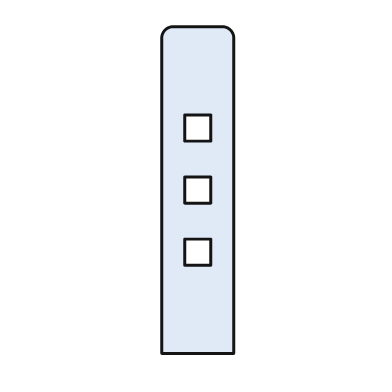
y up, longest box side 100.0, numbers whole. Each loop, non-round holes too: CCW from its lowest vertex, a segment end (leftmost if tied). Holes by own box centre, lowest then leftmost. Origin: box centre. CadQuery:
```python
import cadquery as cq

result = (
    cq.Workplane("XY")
    .moveTo(-11.0, -50.0)
    .lineTo(11.0, -50.0)
    .lineTo(11.0, 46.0)
    .threePointArc((10.0, 49.0), (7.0, 50.0))
    .lineTo(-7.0, 50.0)
    .threePointArc((-10.0, 49.0), (-11.0, 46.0))
    .close()
    .moveTo(-4.0, -23.0)
    .lineTo(4.0, -23.0)
    .lineTo(4.0, -15.0)
    .lineTo(-4.0, -15.0)
    .close()
    .moveTo(-4.0, -4.0)
    .lineTo(4.0, -4.0)
    .lineTo(4.0, 4.0)
    .lineTo(-4.0, 4.0)
    .close()
    .moveTo(-4.0, 15.0)
    .lineTo(4.0, 15.0)
    .lineTo(4.0, 23.0)
    .lineTo(-4.0, 23.0)
    .close()
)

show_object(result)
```